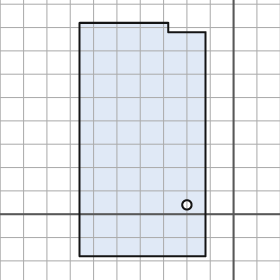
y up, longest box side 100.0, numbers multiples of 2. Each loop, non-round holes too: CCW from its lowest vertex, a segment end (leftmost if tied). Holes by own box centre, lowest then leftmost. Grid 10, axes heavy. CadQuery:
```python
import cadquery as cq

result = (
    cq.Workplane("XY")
    .moveTo(-66.0, -18.0)
    .lineTo(-12.0, -18.0)
    .lineTo(-12.0, 78.0)
    .lineTo(-28.0, 78.0)
    .lineTo(-28.0, 82.0)
    .lineTo(-66.0, 82.0)
    .close()
    .moveTo(-20.0, 4.0)
    .circle(2.0)
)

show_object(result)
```